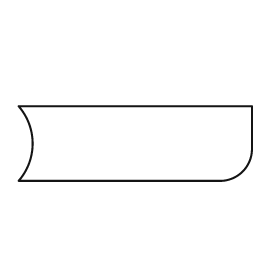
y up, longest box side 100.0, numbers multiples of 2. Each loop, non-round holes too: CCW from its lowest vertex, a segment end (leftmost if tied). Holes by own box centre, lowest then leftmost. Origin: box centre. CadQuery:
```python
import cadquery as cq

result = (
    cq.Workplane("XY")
    .moveTo(-50.0, -16.0)
    .lineTo(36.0, -16.0)
    .threePointArc((46.0, -12.0), (50.0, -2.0))
    .lineTo(50.0, 16.0)
    .lineTo(-50.0, 16.0)
    .threePointArc((-44.0, 0.0), (-50.0, -16.0))
    .close()
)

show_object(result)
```